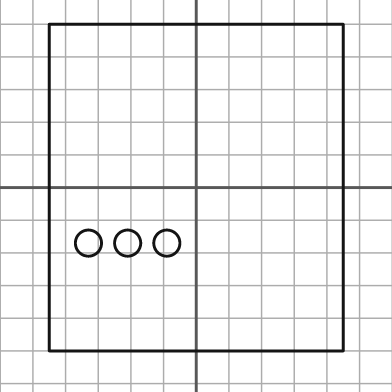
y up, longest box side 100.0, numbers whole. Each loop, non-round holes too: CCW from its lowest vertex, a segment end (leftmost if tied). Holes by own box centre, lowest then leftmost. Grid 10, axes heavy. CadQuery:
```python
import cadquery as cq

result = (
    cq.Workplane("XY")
    .moveTo(-45.0, -50.0)
    .lineTo(45.0, -50.0)
    .lineTo(45.0, 50.0)
    .lineTo(-45.0, 50.0)
    .close()
    .moveTo(-33.0, -17.0)
    .circle(4.0)
    .moveTo(-21.0, -17.0)
    .circle(4.0)
    .moveTo(-9.0, -17.0)
    .circle(4.0)
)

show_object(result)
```